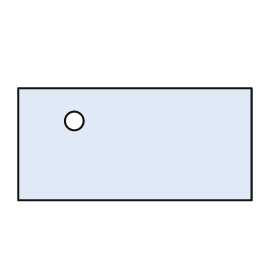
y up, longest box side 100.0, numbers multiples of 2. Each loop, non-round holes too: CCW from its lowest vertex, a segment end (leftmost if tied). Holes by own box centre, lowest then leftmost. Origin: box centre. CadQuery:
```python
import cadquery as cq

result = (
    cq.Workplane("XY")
    .moveTo(-50.0, -24.0)
    .lineTo(50.0, -24.0)
    .lineTo(50.0, 24.0)
    .lineTo(-50.0, 24.0)
    .close()
    .moveTo(-26.0, 10.0)
    .circle(4.0)
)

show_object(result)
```